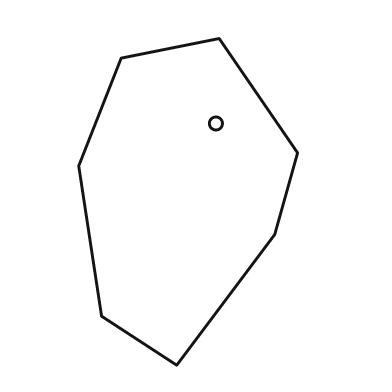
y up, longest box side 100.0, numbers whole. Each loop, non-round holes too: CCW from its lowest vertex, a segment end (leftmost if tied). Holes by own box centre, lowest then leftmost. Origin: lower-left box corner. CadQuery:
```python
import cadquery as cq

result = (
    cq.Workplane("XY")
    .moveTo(30.0, 0.0)
    .lineTo(60.0, 40.0)
    .lineTo(67.0, 65.0)
    .lineTo(43.0, 100.0)
    .lineTo(13.0, 94.0)
    .lineTo(0.0, 61.0)
    .lineTo(7.0, 15.0)
    .close()
    .moveTo(42.0, 74.0)
    .circle(2.0)
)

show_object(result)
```